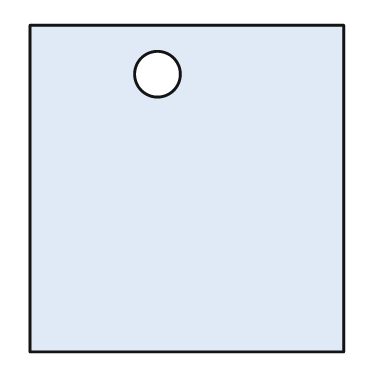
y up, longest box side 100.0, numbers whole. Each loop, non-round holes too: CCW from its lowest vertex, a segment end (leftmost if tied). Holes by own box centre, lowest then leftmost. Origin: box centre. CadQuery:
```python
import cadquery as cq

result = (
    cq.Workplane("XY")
    .moveTo(-48.0, -50.0)
    .lineTo(48.0, -50.0)
    .lineTo(48.0, 50.0)
    .lineTo(-48.0, 50.0)
    .close()
    .moveTo(-9.0, 35.0)
    .circle(7.0)
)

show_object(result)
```